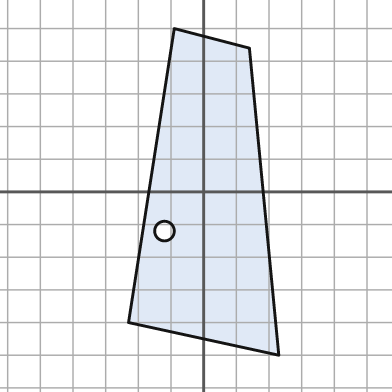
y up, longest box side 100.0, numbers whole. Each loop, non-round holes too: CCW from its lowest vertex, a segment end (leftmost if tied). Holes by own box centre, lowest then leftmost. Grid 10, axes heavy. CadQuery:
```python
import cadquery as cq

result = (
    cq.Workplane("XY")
    .moveTo(23.0, -50.0)
    .lineTo(14.0, 44.0)
    .lineTo(-9.0, 50.0)
    .lineTo(-23.0, -40.0)
    .close()
    .moveTo(-12.0, -12.0)
    .circle(3.0)
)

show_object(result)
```